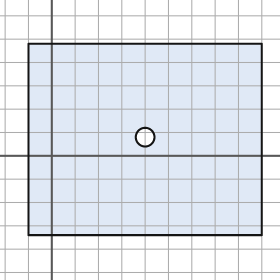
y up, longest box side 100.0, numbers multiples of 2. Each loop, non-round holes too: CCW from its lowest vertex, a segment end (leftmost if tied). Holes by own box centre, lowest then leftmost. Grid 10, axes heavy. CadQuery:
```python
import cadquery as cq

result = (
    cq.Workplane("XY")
    .moveTo(-10.0, -34.0)
    .lineTo(90.0, -34.0)
    .lineTo(90.0, 48.0)
    .lineTo(-10.0, 48.0)
    .close()
    .moveTo(40.0, 8.0)
    .circle(4.0)
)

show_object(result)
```